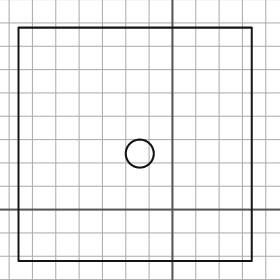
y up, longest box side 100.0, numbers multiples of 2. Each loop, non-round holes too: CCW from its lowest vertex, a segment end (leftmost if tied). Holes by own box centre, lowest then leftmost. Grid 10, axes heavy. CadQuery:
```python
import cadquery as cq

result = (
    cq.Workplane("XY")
    .moveTo(-66.0, -22.0)
    .lineTo(34.0, -22.0)
    .lineTo(34.0, 78.0)
    .lineTo(-66.0, 78.0)
    .close()
    .moveTo(-14.0, 24.0)
    .circle(6.0)
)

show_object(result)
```